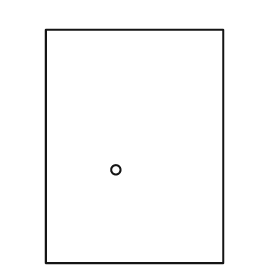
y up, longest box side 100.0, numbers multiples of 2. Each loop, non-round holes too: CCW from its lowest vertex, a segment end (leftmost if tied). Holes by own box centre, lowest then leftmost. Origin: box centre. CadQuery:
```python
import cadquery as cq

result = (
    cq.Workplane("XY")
    .moveTo(-38.0, -50.0)
    .lineTo(38.0, -50.0)
    .lineTo(38.0, 50.0)
    .lineTo(-38.0, 50.0)
    .close()
    .moveTo(-8.0, -10.0)
    .circle(2.0)
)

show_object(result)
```